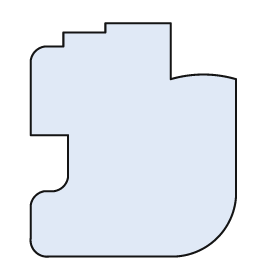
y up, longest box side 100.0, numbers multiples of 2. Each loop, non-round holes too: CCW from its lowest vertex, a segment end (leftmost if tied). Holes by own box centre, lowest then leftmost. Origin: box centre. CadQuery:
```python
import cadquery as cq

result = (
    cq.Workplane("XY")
    .moveTo(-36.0, -50.0)
    .lineTo(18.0, -50.0)
    .threePointArc((36.0, -42.0), (44.0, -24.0))
    .lineTo(44.0, 26.0)
    .threePointArc((30.0, 28.0), (16.0, 26.0))
    .lineTo(16.0, 50.0)
    .lineTo(-12.0, 50.0)
    .lineTo(-12.0, 46.0)
    .lineTo(-30.0, 46.0)
    .lineTo(-30.0, 40.0)
    .lineTo(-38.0, 40.0)
    .threePointArc((-42.0, 38.0), (-44.0, 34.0))
    .lineTo(-44.0, 2.0)
    .lineTo(-28.0, 2.0)
    .lineTo(-28.0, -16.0)
    .threePointArc((-30.0, -20.0), (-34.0, -22.0))
    .lineTo(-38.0, -22.0)
    .threePointArc((-42.0, -24.0), (-44.0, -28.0))
    .lineTo(-44.0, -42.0)
    .threePointArc((-42.0, -48.0), (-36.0, -50.0))
    .close()
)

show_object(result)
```